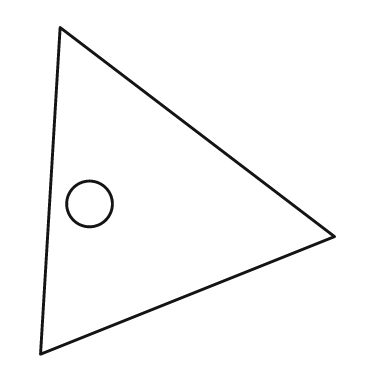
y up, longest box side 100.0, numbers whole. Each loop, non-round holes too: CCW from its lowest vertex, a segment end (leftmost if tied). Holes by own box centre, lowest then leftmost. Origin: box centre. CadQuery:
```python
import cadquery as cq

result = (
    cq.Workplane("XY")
    .moveTo(-45.0, -50.0)
    .lineTo(45.0, -14.0)
    .lineTo(-39.0, 50.0)
    .close()
    .moveTo(-30.0, -4.0)
    .circle(7.0)
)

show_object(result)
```